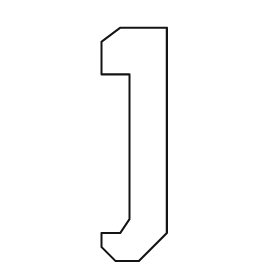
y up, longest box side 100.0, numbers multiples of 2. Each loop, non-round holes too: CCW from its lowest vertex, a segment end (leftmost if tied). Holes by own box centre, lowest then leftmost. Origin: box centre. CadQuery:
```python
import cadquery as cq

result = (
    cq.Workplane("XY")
    .moveTo(-8.0, -50.0)
    .lineTo(2.0, -50.0)
    .lineTo(14.0, -38.0)
    .lineTo(14.0, 50.0)
    .lineTo(-6.0, 50.0)
    .lineTo(-14.0, 44.0)
    .lineTo(-14.0, 30.0)
    .lineTo(-2.0, 30.0)
    .lineTo(-2.0, -32.0)
    .lineTo(-6.0, -38.0)
    .lineTo(-14.0, -38.0)
    .lineTo(-14.0, -44.0)
    .close()
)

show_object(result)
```